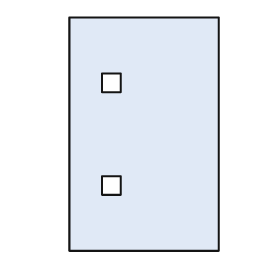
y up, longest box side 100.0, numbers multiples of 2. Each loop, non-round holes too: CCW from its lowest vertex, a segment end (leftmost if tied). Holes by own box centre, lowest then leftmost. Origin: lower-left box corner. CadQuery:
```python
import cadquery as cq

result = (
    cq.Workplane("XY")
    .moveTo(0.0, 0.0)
    .lineTo(64.0, 0.0)
    .lineTo(64.0, 100.0)
    .lineTo(0.0, 100.0)
    .close()
    .moveTo(14.0, 24.0)
    .lineTo(22.0, 24.0)
    .lineTo(22.0, 32.0)
    .lineTo(14.0, 32.0)
    .close()
    .moveTo(14.0, 68.0)
    .lineTo(22.0, 68.0)
    .lineTo(22.0, 76.0)
    .lineTo(14.0, 76.0)
    .close()
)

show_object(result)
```